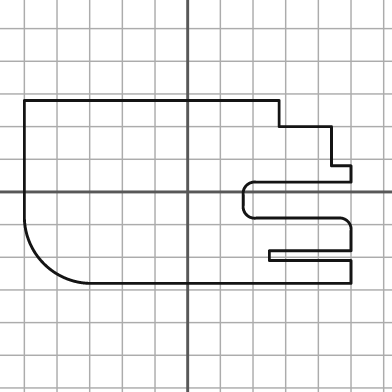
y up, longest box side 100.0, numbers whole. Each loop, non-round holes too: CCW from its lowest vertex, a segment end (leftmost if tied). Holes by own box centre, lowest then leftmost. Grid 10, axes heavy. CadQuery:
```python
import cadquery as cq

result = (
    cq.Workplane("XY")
    .moveTo(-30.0, -28.0)
    .lineTo(50.0, -28.0)
    .lineTo(50.0, -21.0)
    .lineTo(25.0, -21.0)
    .lineTo(25.0, -18.0)
    .lineTo(50.0, -18.0)
    .lineTo(50.0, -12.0)
    .threePointArc((49.0, -9.0), (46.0, -8.0))
    .lineTo(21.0, -8.0)
    .threePointArc((18.0, -7.0), (17.0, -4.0))
    .lineTo(17.0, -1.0)
    .threePointArc((18.0, 2.0), (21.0, 3.0))
    .lineTo(50.0, 3.0)
    .lineTo(50.0, 8.0)
    .lineTo(44.0, 8.0)
    .lineTo(44.0, 20.0)
    .lineTo(28.0, 20.0)
    .lineTo(28.0, 28.0)
    .lineTo(-50.0, 28.0)
    .lineTo(-50.0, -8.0)
    .threePointArc((-44.0, -22.0), (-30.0, -28.0))
    .close()
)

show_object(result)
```